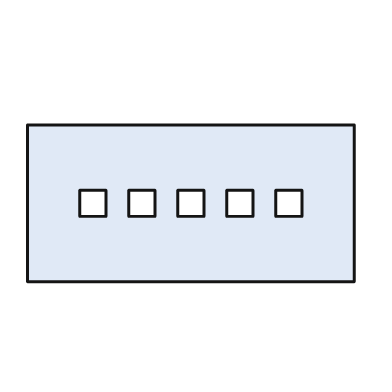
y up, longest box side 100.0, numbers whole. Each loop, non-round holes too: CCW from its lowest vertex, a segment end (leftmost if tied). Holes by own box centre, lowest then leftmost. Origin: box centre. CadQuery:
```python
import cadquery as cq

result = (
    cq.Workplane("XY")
    .moveTo(-50.0, -24.0)
    .lineTo(50.0, -24.0)
    .lineTo(50.0, 24.0)
    .lineTo(-50.0, 24.0)
    .close()
    .moveTo(-34.0, -4.0)
    .lineTo(-26.0, -4.0)
    .lineTo(-26.0, 4.0)
    .lineTo(-34.0, 4.0)
    .close()
    .moveTo(-19.0, -4.0)
    .lineTo(-11.0, -4.0)
    .lineTo(-11.0, 4.0)
    .lineTo(-19.0, 4.0)
    .close()
    .moveTo(-4.0, -4.0)
    .lineTo(4.0, -4.0)
    .lineTo(4.0, 4.0)
    .lineTo(-4.0, 4.0)
    .close()
    .moveTo(11.0, -4.0)
    .lineTo(19.0, -4.0)
    .lineTo(19.0, 4.0)
    .lineTo(11.0, 4.0)
    .close()
    .moveTo(26.0, -4.0)
    .lineTo(34.0, -4.0)
    .lineTo(34.0, 4.0)
    .lineTo(26.0, 4.0)
    .close()
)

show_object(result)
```